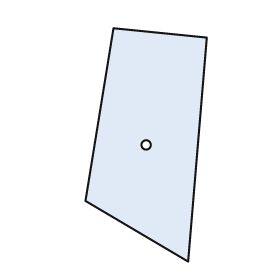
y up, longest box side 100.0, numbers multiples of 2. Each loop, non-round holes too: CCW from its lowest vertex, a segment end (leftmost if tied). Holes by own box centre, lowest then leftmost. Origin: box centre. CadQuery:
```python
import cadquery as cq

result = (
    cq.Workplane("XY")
    .moveTo(18.0, -50.0)
    .lineTo(26.0, 46.0)
    .lineTo(-14.0, 50.0)
    .lineTo(-26.0, -24.0)
    .close()
    .moveTo(0.0, 0.0)
    .circle(2.0)
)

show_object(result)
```